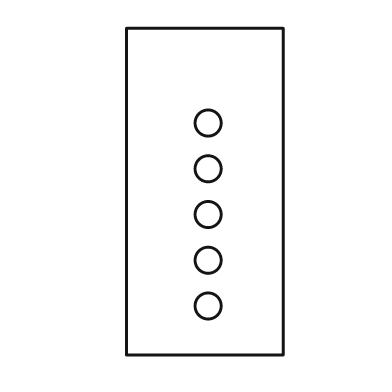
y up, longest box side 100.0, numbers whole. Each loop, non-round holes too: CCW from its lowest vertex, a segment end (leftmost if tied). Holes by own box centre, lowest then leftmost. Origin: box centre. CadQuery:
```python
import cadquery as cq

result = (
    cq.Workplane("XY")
    .moveTo(-24.0, -50.0)
    .lineTo(24.0, -50.0)
    .lineTo(24.0, 50.0)
    .lineTo(-24.0, 50.0)
    .close()
    .moveTo(1.0, -35.0)
    .circle(4.0)
    .moveTo(1.0, -21.0)
    .circle(4.0)
    .moveTo(1.0, -7.0)
    .circle(4.0)
    .moveTo(1.0, 7.0)
    .circle(4.0)
    .moveTo(1.0, 21.0)
    .circle(4.0)
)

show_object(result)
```